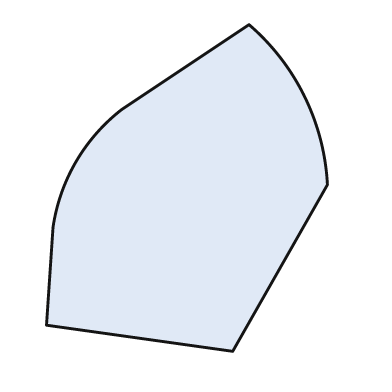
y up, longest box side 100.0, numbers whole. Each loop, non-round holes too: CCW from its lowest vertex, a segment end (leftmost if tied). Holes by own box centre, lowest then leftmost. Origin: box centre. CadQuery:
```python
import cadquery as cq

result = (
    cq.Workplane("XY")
    .moveTo(14.0, -50.0)
    .lineTo(43.0, 1.0)
    .threePointArc((36.0, 28.0), (19.0, 50.0))
    .lineTo(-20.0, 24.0)
    .threePointArc((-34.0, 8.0), (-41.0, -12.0))
    .lineTo(-43.0, -42.0)
    .close()
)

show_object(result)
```